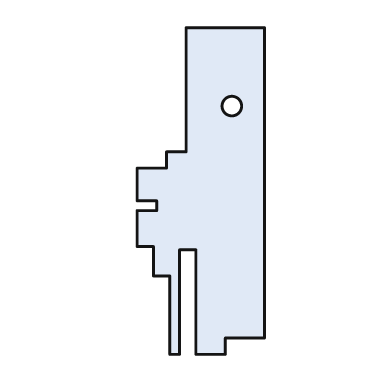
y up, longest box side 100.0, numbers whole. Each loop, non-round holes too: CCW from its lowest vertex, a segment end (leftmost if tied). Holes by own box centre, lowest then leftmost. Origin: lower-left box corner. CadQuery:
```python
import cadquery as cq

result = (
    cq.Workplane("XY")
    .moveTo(10.0, 0.0)
    .lineTo(13.0, 0.0)
    .lineTo(13.0, 32.0)
    .lineTo(18.0, 32.0)
    .lineTo(18.0, 0.0)
    .lineTo(27.0, 0.0)
    .lineTo(27.0, 5.0)
    .lineTo(39.0, 5.0)
    .lineTo(39.0, 100.0)
    .lineTo(15.0, 100.0)
    .lineTo(15.0, 62.0)
    .lineTo(9.0, 62.0)
    .lineTo(9.0, 57.0)
    .lineTo(0.0, 57.0)
    .lineTo(0.0, 47.0)
    .lineTo(6.0, 47.0)
    .lineTo(6.0, 44.0)
    .lineTo(0.0, 44.0)
    .lineTo(0.0, 33.0)
    .lineTo(5.0, 33.0)
    .lineTo(5.0, 24.0)
    .lineTo(10.0, 24.0)
    .close()
    .moveTo(29.0, 76.0)
    .circle(3.0)
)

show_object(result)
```